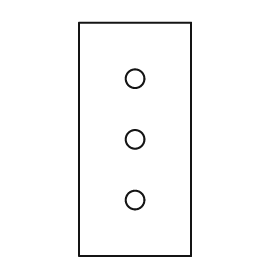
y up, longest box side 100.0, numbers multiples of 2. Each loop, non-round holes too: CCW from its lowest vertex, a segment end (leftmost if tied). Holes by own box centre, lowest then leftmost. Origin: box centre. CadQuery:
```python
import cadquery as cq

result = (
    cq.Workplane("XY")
    .moveTo(-24.0, -50.0)
    .lineTo(24.0, -50.0)
    .lineTo(24.0, 50.0)
    .lineTo(-24.0, 50.0)
    .close()
    .moveTo(0.0, -26.0)
    .circle(4.0)
    .moveTo(0.0, 0.0)
    .circle(4.0)
    .moveTo(0.0, 26.0)
    .circle(4.0)
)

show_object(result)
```